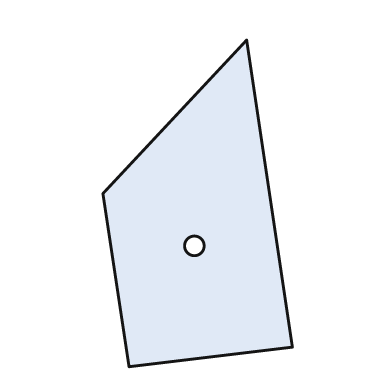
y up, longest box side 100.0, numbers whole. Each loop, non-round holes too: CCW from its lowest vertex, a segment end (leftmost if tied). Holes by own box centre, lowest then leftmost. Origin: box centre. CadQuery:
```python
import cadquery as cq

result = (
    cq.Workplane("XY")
    .moveTo(-21.0, -50.0)
    .lineTo(29.0, -44.0)
    .lineTo(15.0, 50.0)
    .lineTo(-29.0, 3.0)
    .close()
    .moveTo(-1.0, -13.0)
    .circle(3.0)
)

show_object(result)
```